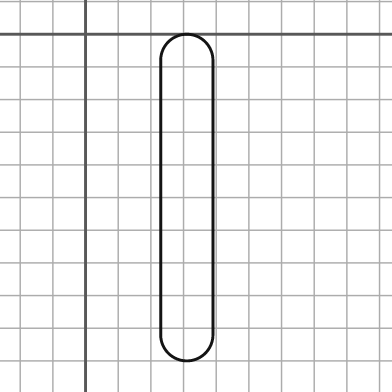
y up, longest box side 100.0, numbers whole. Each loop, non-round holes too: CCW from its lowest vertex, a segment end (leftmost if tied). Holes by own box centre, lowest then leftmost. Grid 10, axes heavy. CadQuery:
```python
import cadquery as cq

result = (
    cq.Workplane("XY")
    .moveTo(23.0, -92.0)
    .threePointArc((31.0, -100.0), (39.0, -92.0))
    .lineTo(39.0, -8.0)
    .threePointArc((31.0, 0.0), (23.0, -8.0))
    .close()
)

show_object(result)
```